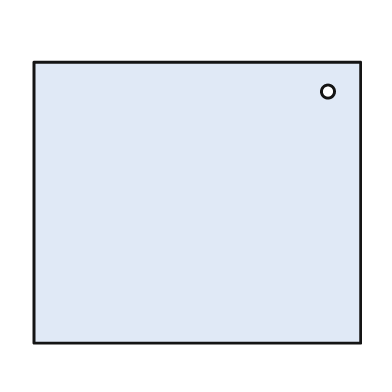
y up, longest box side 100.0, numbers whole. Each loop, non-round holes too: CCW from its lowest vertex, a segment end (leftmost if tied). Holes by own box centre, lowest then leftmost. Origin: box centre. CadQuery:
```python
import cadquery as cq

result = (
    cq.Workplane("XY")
    .moveTo(-50.0, -43.0)
    .lineTo(50.0, -43.0)
    .lineTo(50.0, 43.0)
    .lineTo(-50.0, 43.0)
    .close()
    .moveTo(40.0, 34.0)
    .circle(2.0)
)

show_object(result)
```